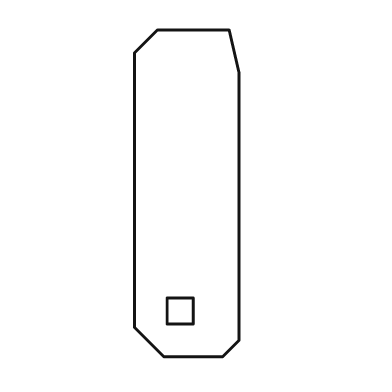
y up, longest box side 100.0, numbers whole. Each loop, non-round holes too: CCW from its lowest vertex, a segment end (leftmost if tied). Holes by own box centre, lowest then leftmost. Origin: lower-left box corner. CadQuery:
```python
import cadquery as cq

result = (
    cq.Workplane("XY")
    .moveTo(9.0, 0.0)
    .lineTo(27.0, 0.0)
    .lineTo(32.0, 5.0)
    .lineTo(32.0, 87.0)
    .lineTo(29.0, 100.0)
    .lineTo(7.0, 100.0)
    .lineTo(0.0, 93.0)
    .lineTo(0.0, 9.0)
    .close()
    .moveTo(10.0, 10.0)
    .lineTo(18.0, 10.0)
    .lineTo(18.0, 18.0)
    .lineTo(10.0, 18.0)
    .close()
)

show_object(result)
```